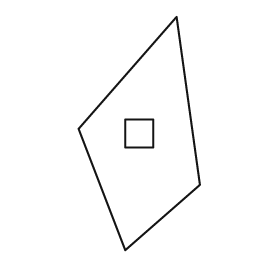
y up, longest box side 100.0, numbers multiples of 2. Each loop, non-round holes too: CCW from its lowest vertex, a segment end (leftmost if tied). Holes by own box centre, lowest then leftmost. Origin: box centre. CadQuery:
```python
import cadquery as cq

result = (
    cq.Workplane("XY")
    .moveTo(-6.0, -50.0)
    .lineTo(26.0, -22.0)
    .lineTo(16.0, 50.0)
    .lineTo(-26.0, 2.0)
    .close()
    .moveTo(-6.0, -6.0)
    .lineTo(6.0, -6.0)
    .lineTo(6.0, 6.0)
    .lineTo(-6.0, 6.0)
    .close()
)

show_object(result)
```